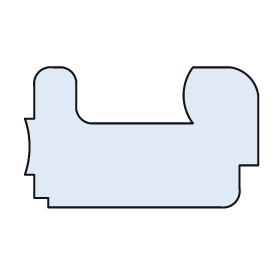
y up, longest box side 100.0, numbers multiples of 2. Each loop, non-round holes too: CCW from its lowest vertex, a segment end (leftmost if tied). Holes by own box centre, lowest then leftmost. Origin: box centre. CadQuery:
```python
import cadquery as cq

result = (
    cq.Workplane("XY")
    .moveTo(-40.0, -30.0)
    .lineTo(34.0, -30.0)
    .threePointArc((40.0, -28.0), (42.0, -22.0))
    .lineTo(42.0, -12.0)
    .lineTo(50.0, -12.0)
    .lineTo(50.0, 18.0)
    .threePointArc((46.0, 26.0), (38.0, 30.0))
    .lineTo(22.0, 30.0)
    .threePointArc((18.0, 18.0), (22.0, 6.0))
    .lineTo(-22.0, 6.0)
    .threePointArc((-26.0, 8.0), (-28.0, 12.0))
    .lineTo(-28.0, 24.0)
    .threePointArc((-30.0, 28.0), (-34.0, 30.0))
    .lineTo(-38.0, 30.0)
    .threePointArc((-44.0, 28.0), (-46.0, 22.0))
    .lineTo(-46.0, 8.0)
    .lineTo(-50.0, 8.0)
    .threePointArc((-48.0, -4.0), (-50.0, -16.0))
    .lineTo(-46.0, -16.0)
    .lineTo(-46.0, -26.0)
    .lineTo(-40.0, -26.0)
    .close()
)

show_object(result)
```